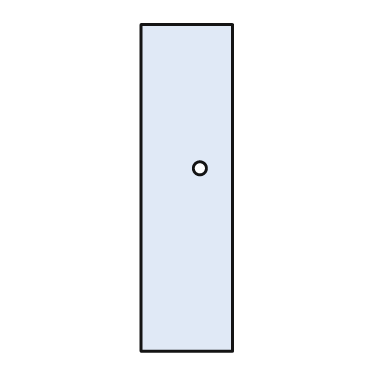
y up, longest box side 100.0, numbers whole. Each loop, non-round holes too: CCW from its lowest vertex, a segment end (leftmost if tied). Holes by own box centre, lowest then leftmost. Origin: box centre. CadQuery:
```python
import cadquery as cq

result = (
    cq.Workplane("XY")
    .moveTo(-14.0, -50.0)
    .lineTo(14.0, -50.0)
    .lineTo(14.0, 50.0)
    .lineTo(-14.0, 50.0)
    .close()
    .moveTo(4.0, 6.0)
    .circle(2.0)
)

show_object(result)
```